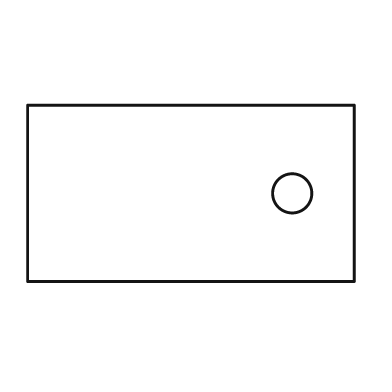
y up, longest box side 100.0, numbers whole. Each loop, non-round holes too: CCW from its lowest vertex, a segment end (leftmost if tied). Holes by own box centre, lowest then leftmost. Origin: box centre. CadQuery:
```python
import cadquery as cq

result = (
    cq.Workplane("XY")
    .moveTo(-50.0, -27.0)
    .lineTo(50.0, -27.0)
    .lineTo(50.0, 27.0)
    .lineTo(-50.0, 27.0)
    .close()
    .moveTo(31.0, 0.0)
    .circle(6.0)
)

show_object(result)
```